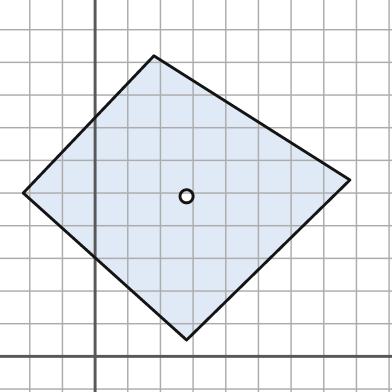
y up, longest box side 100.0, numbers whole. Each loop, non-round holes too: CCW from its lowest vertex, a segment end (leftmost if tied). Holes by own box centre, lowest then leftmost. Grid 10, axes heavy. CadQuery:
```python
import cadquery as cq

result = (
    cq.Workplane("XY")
    .moveTo(28.0, 5.0)
    .lineTo(78.0, 54.0)
    .lineTo(18.0, 92.0)
    .lineTo(-22.0, 50.0)
    .close()
    .moveTo(28.0, 49.0)
    .circle(2.0)
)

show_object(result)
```